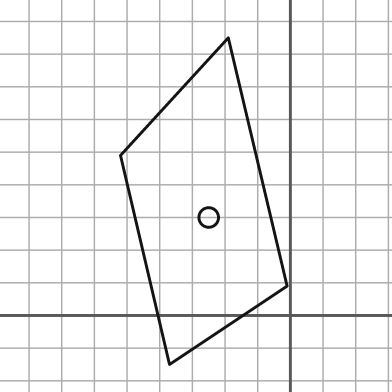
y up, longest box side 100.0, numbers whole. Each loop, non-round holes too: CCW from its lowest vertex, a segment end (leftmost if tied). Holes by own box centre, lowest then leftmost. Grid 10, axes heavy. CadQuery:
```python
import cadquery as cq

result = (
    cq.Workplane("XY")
    .moveTo(-37.0, -15.0)
    .lineTo(-1.0, 9.0)
    .lineTo(-19.0, 85.0)
    .lineTo(-52.0, 49.0)
    .close()
    .moveTo(-25.0, 30.0)
    .circle(3.0)
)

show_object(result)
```